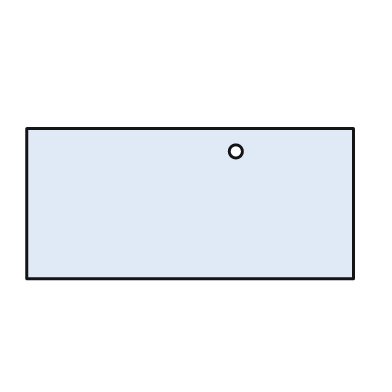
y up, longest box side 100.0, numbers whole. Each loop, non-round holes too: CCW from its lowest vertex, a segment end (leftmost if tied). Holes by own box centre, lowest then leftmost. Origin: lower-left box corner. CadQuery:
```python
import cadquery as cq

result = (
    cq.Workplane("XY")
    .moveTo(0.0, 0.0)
    .lineTo(100.0, 0.0)
    .lineTo(100.0, 46.0)
    .lineTo(0.0, 46.0)
    .close()
    .moveTo(64.0, 39.0)
    .circle(2.0)
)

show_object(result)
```